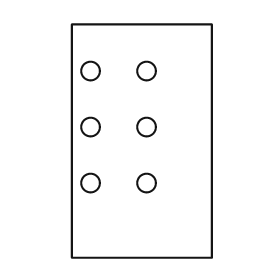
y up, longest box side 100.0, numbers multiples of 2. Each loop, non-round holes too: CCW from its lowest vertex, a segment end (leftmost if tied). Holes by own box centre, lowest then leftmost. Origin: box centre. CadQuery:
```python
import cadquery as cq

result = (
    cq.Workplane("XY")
    .moveTo(-30.0, -50.0)
    .lineTo(30.0, -50.0)
    .lineTo(30.0, 50.0)
    .lineTo(-30.0, 50.0)
    .close()
    .moveTo(-22.0, -18.0)
    .circle(4.0)
    .moveTo(2.0, -18.0)
    .circle(4.0)
    .moveTo(-22.0, 6.0)
    .circle(4.0)
    .moveTo(2.0, 6.0)
    .circle(4.0)
    .moveTo(-22.0, 30.0)
    .circle(4.0)
    .moveTo(2.0, 30.0)
    .circle(4.0)
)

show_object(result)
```